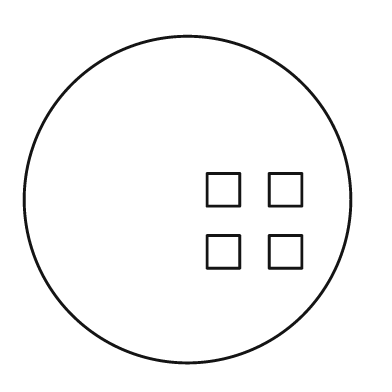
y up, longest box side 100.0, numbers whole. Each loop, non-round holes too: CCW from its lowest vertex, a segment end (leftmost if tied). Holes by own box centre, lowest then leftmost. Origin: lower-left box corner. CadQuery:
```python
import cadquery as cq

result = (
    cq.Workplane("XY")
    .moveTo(50.0, 50.0)
    .circle(50.0)
    .moveTo(56.0, 29.0)
    .lineTo(66.0, 29.0)
    .lineTo(66.0, 39.0)
    .lineTo(56.0, 39.0)
    .close()
    .moveTo(75.0, 29.0)
    .lineTo(85.0, 29.0)
    .lineTo(85.0, 39.0)
    .lineTo(75.0, 39.0)
    .close()
    .moveTo(56.0, 48.0)
    .lineTo(66.0, 48.0)
    .lineTo(66.0, 58.0)
    .lineTo(56.0, 58.0)
    .close()
    .moveTo(75.0, 48.0)
    .lineTo(85.0, 48.0)
    .lineTo(85.0, 58.0)
    .lineTo(75.0, 58.0)
    .close()
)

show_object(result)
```